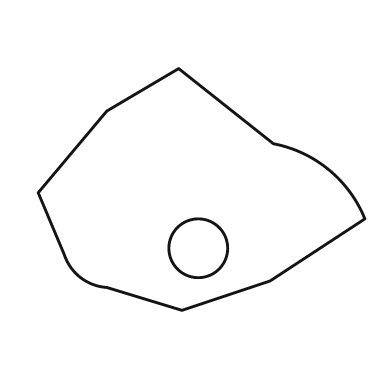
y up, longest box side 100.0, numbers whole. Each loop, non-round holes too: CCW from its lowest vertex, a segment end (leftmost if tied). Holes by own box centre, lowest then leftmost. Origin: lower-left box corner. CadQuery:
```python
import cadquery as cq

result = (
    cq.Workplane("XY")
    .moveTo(44.0, 0.0)
    .lineTo(71.0, 9.0)
    .lineTo(100.0, 28.0)
    .threePointArc((89.0, 43.0), (72.0, 51.0))
    .lineTo(43.0, 74.0)
    .lineTo(21.0, 61.0)
    .lineTo(0.0, 36.0)
    .lineTo(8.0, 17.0)
    .threePointArc((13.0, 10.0), (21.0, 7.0))
    .close()
    .moveTo(49.0, 19.0)
    .circle(9.0)
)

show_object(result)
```